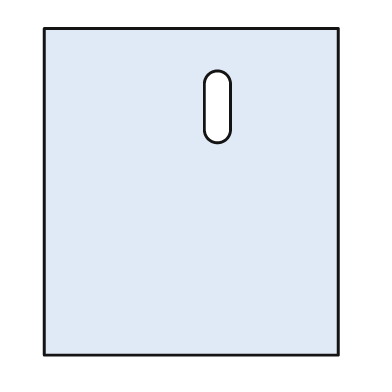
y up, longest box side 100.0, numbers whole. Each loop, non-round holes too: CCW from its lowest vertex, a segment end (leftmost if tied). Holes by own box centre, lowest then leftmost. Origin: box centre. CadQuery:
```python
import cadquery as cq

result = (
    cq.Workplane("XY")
    .moveTo(-45.0, -50.0)
    .lineTo(45.0, -50.0)
    .lineTo(45.0, 50.0)
    .lineTo(-45.0, 50.0)
    .close()
    .moveTo(4.0, 19.0)
    .threePointArc((8.0, 15.0), (12.0, 19.0))
    .lineTo(12.0, 33.0)
    .threePointArc((8.0, 37.0), (4.0, 33.0))
    .close()
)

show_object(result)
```